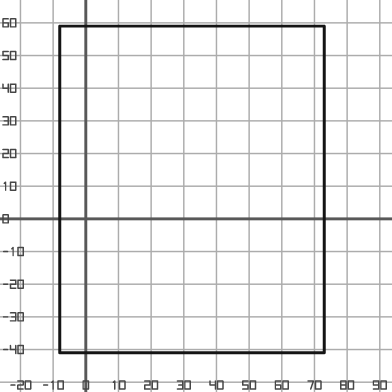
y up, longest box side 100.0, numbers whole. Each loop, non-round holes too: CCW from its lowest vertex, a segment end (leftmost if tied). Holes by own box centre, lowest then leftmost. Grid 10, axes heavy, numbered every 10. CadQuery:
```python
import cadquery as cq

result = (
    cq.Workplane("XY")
    .moveTo(-8.0, -41.0)
    .lineTo(73.0, -41.0)
    .lineTo(73.0, 59.0)
    .lineTo(-8.0, 59.0)
    .close()
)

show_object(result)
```